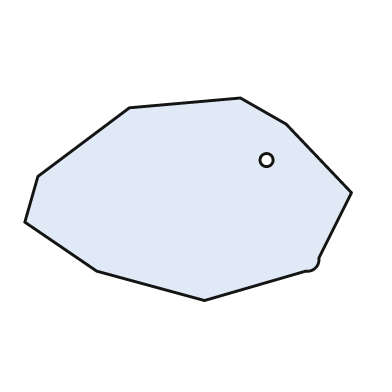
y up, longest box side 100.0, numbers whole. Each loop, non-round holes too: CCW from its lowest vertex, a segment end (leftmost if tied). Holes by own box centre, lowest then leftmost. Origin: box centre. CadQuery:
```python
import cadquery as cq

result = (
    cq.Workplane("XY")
    .moveTo(5.0, -31.0)
    .lineTo(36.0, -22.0)
    .threePointArc((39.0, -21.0), (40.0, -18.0))
    .lineTo(50.0, 2.0)
    .lineTo(30.0, 23.0)
    .lineTo(16.0, 31.0)
    .lineTo(-18.0, 28.0)
    .lineTo(-46.0, 7.0)
    .lineTo(-50.0, -7.0)
    .lineTo(-28.0, -22.0)
    .close()
    .moveTo(24.0, 12.0)
    .circle(2.0)
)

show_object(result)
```